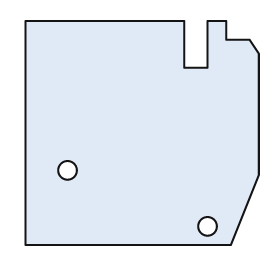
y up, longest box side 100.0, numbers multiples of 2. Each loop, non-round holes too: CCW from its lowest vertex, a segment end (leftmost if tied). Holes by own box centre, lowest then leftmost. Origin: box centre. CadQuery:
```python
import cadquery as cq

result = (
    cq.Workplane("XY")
    .moveTo(-50.0, -48.0)
    .lineTo(38.0, -48.0)
    .lineTo(50.0, -18.0)
    .lineTo(50.0, 34.0)
    .lineTo(46.0, 40.0)
    .lineTo(36.0, 40.0)
    .lineTo(36.0, 48.0)
    .lineTo(28.0, 48.0)
    .lineTo(28.0, 28.0)
    .lineTo(18.0, 28.0)
    .lineTo(18.0, 48.0)
    .lineTo(-50.0, 48.0)
    .close()
    .moveTo(28.0, -40.0)
    .circle(4.0)
    .moveTo(-32.0, -16.0)
    .circle(4.0)
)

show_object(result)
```